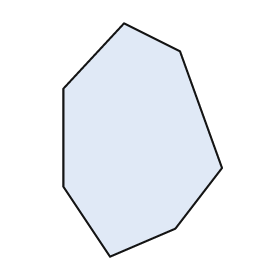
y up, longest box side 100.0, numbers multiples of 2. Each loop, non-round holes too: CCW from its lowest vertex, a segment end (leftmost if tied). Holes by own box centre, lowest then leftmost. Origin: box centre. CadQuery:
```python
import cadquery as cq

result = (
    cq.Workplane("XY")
    .moveTo(-14.0, -50.0)
    .lineTo(14.0, -38.0)
    .lineTo(34.0, -12.0)
    .lineTo(16.0, 38.0)
    .lineTo(-8.0, 50.0)
    .lineTo(-34.0, 22.0)
    .lineTo(-34.0, -20.0)
    .close()
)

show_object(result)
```